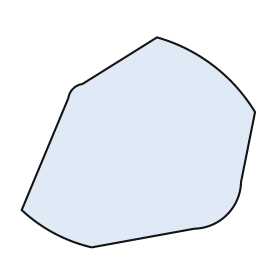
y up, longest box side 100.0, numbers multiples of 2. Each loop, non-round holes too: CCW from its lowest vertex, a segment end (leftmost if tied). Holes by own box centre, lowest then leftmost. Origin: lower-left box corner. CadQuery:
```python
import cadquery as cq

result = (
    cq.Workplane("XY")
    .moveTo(30.0, 0.0)
    .lineTo(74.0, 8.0)
    .threePointArc((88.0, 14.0), (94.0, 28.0))
    .lineTo(100.0, 58.0)
    .threePointArc((82.0, 78.0), (58.0, 90.0))
    .lineTo(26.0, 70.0)
    .threePointArc((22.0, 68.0), (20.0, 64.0))
    .lineTo(0.0, 16.0)
    .threePointArc((14.0, 6.0), (30.0, 0.0))
    .close()
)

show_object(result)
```